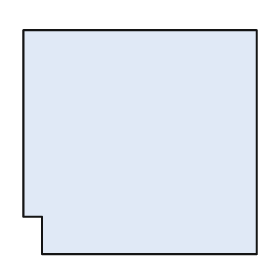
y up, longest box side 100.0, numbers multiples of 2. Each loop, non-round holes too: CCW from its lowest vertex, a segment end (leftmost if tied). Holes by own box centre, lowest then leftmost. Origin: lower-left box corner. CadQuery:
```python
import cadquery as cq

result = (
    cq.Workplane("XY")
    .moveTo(8.0, 0.0)
    .lineTo(100.0, 0.0)
    .lineTo(100.0, 96.0)
    .lineTo(0.0, 96.0)
    .lineTo(0.0, 16.0)
    .lineTo(8.0, 16.0)
    .close()
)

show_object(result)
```